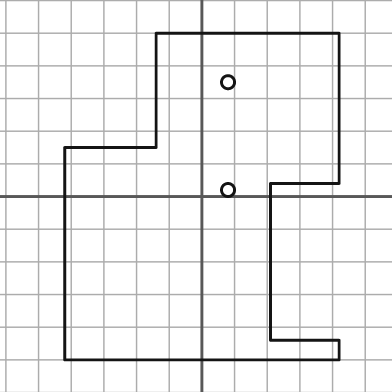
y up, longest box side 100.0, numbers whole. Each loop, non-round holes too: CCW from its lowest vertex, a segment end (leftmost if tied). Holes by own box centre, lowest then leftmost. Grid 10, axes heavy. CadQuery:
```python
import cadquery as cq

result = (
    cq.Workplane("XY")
    .moveTo(-42.0, -50.0)
    .lineTo(42.0, -50.0)
    .lineTo(42.0, -44.0)
    .lineTo(21.0, -44.0)
    .lineTo(21.0, 4.0)
    .lineTo(42.0, 4.0)
    .lineTo(42.0, 50.0)
    .lineTo(-14.0, 50.0)
    .lineTo(-14.0, 15.0)
    .lineTo(-42.0, 15.0)
    .close()
    .moveTo(8.0, 2.0)
    .circle(2.0)
    .moveTo(8.0, 35.0)
    .circle(2.0)
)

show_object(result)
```